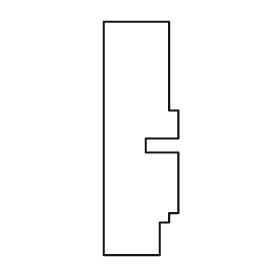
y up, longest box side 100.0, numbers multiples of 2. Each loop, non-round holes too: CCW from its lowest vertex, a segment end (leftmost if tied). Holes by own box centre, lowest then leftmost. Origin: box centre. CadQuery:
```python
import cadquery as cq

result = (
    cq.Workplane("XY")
    .moveTo(-16.0, -50.0)
    .lineTo(8.0, -50.0)
    .lineTo(8.0, -36.0)
    .lineTo(12.0, -36.0)
    .lineTo(12.0, -32.0)
    .lineTo(16.0, -32.0)
    .lineTo(16.0, -6.0)
    .lineTo(2.0, -6.0)
    .lineTo(2.0, 0.0)
    .lineTo(16.0, 0.0)
    .lineTo(16.0, 12.0)
    .lineTo(12.0, 12.0)
    .lineTo(12.0, 50.0)
    .lineTo(-16.0, 50.0)
    .close()
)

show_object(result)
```